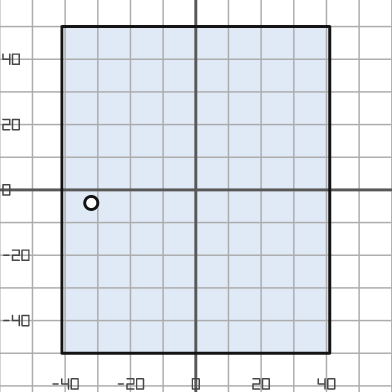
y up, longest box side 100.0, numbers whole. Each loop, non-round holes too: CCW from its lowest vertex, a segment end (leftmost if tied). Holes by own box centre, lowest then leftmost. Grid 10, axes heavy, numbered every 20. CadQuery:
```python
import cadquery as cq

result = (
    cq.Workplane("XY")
    .moveTo(-41.0, -50.0)
    .lineTo(41.0, -50.0)
    .lineTo(41.0, 50.0)
    .lineTo(-41.0, 50.0)
    .close()
    .moveTo(-32.0, -4.0)
    .circle(2.0)
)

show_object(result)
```